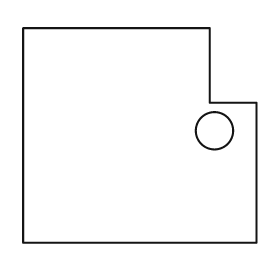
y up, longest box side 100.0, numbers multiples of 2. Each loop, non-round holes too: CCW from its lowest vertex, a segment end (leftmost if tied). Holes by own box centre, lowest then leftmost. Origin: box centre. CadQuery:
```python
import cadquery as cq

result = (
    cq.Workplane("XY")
    .moveTo(-50.0, -46.0)
    .lineTo(50.0, -46.0)
    .lineTo(50.0, 14.0)
    .lineTo(30.0, 14.0)
    .lineTo(30.0, 46.0)
    .lineTo(-50.0, 46.0)
    .close()
    .moveTo(32.0, 2.0)
    .circle(8.0)
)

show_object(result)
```